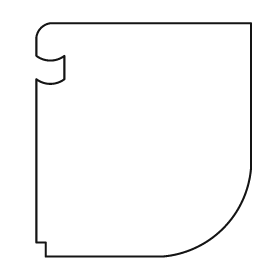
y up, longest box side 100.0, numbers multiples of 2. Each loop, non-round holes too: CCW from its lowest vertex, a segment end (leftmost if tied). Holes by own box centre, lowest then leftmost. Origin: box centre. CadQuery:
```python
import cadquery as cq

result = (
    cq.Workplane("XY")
    .moveTo(-42.0, -50.0)
    .lineTo(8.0, -50.0)
    .threePointArc((34.0, -38.0), (46.0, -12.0))
    .lineTo(46.0, 50.0)
    .lineTo(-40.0, 50.0)
    .threePointArc((-44.0, 48.0), (-46.0, 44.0))
    .lineTo(-46.0, 36.0)
    .threePointArc((-40.0, 34.0), (-34.0, 36.0))
    .lineTo(-34.0, 26.0)
    .threePointArc((-40.0, 24.0), (-46.0, 26.0))
    .lineTo(-46.0, -44.0)
    .lineTo(-42.0, -44.0)
    .close()
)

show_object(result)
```